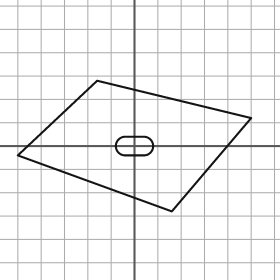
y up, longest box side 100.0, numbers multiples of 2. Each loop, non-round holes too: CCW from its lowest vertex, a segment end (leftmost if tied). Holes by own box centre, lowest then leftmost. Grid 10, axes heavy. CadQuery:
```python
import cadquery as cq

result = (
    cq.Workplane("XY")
    .moveTo(16.0, -28.0)
    .lineTo(50.0, 12.0)
    .lineTo(-16.0, 28.0)
    .lineTo(-50.0, -4.0)
    .close()
    .moveTo(-4.0, -4.0)
    .lineTo(4.0, -4.0)
    .threePointArc((8.0, 0.0), (4.0, 4.0))
    .lineTo(-4.0, 4.0)
    .threePointArc((-8.0, 0.0), (-4.0, -4.0))
    .close()
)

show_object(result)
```